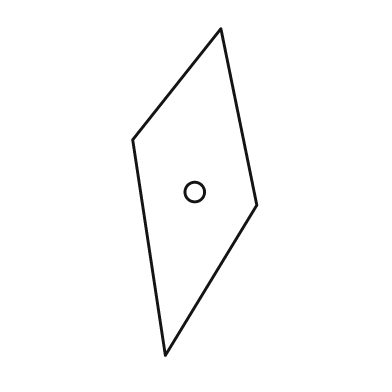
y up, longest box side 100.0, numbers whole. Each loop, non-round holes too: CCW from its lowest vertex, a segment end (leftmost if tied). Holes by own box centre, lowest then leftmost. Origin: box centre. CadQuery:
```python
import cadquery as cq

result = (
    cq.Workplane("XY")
    .moveTo(-9.0, -50.0)
    .lineTo(19.0, -4.0)
    .lineTo(8.0, 50.0)
    .lineTo(-19.0, 16.0)
    .close()
    .moveTo(0.0, 0.0)
    .circle(3.0)
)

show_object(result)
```